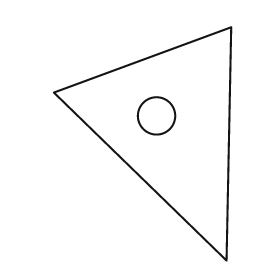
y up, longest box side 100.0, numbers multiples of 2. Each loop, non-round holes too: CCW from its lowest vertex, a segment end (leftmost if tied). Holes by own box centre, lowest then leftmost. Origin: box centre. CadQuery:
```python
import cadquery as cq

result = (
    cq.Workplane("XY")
    .moveTo(36.0, -50.0)
    .lineTo(38.0, 50.0)
    .lineTo(-38.0, 22.0)
    .close()
    .moveTo(6.0, 12.0)
    .circle(8.0)
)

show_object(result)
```